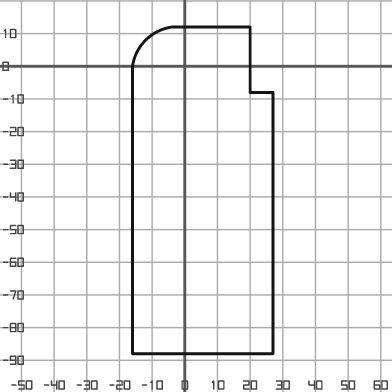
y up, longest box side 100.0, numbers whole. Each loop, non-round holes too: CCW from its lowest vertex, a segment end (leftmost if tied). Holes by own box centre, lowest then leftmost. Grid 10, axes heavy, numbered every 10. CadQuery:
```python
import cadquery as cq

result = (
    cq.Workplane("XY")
    .moveTo(-16.0, -88.0)
    .lineTo(27.0, -88.0)
    .lineTo(27.0, -8.0)
    .lineTo(20.0, -8.0)
    .lineTo(20.0, 12.0)
    .lineTo(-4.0, 12.0)
    .threePointArc((-12.0, 8.0), (-16.0, 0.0))
    .close()
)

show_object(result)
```